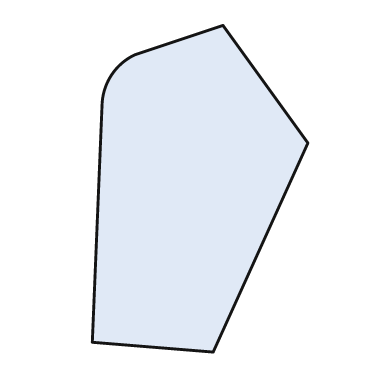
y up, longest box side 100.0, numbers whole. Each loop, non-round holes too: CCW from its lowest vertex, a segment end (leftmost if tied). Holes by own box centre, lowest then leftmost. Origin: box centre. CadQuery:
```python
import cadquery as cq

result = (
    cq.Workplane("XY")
    .moveTo(4.0, -50.0)
    .lineTo(33.0, 14.0)
    .lineTo(7.0, 50.0)
    .lineTo(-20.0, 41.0)
    .threePointArc((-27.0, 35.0), (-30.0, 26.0))
    .lineTo(-33.0, -47.0)
    .close()
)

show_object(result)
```